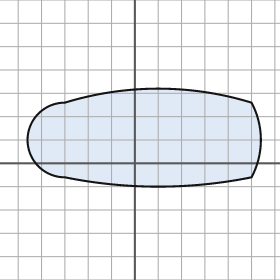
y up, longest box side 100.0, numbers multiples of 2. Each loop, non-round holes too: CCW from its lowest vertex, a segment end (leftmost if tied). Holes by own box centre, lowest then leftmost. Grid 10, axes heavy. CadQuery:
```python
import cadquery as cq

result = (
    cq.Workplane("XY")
    .moveTo(-30.0, -6.0)
    .threePointArc((10.0, -10.0), (50.0, -6.0))
    .threePointArc((54.0, 10.0), (50.0, 26.0))
    .threePointArc((10.0, 32.0), (-30.0, 26.0))
    .threePointArc((-46.0, 10.0), (-30.0, -6.0))
    .close()
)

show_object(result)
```